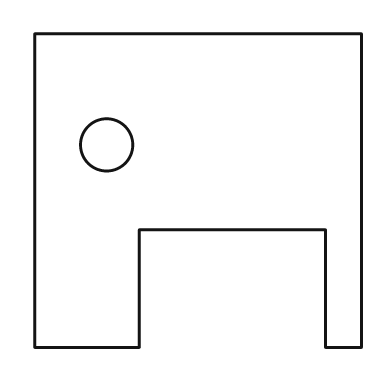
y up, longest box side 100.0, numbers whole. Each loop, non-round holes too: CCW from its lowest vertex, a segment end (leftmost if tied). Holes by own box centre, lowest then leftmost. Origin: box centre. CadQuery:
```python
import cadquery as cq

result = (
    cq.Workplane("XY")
    .moveTo(-50.0, -48.0)
    .lineTo(-18.0, -48.0)
    .lineTo(-18.0, -12.0)
    .lineTo(39.0, -12.0)
    .lineTo(39.0, -48.0)
    .lineTo(50.0, -48.0)
    .lineTo(50.0, 48.0)
    .lineTo(-50.0, 48.0)
    .close()
    .moveTo(-28.0, 14.0)
    .circle(8.0)
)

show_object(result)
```